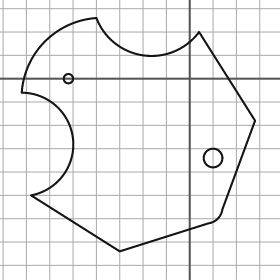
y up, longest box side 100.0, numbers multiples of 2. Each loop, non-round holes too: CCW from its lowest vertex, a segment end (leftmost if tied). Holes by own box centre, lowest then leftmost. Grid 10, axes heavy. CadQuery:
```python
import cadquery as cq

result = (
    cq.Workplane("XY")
    .moveTo(-30.0, -74.0)
    .lineTo(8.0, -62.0)
    .threePointArc((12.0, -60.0), (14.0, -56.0))
    .lineTo(28.0, -18.0)
    .lineTo(4.0, 20.0)
    .threePointArc((-20.0, 10.0), (-40.0, 26.0))
    .threePointArc((-62.0, 16.0), (-72.0, -6.0))
    .threePointArc((-50.0, -26.0), (-68.0, -50.0))
    .close()
    .moveTo(10.0, -34.0)
    .circle(4.0)
    .moveTo(-52.0, 0.0)
    .circle(2.0)
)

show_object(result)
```